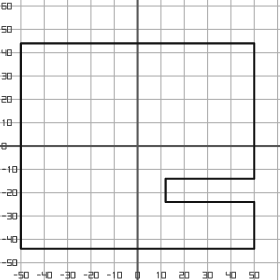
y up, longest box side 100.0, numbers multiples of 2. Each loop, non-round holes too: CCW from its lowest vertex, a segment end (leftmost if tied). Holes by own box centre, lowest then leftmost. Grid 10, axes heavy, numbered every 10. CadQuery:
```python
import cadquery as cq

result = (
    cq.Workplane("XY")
    .moveTo(-50.0, -44.0)
    .lineTo(50.0, -44.0)
    .lineTo(50.0, -24.0)
    .lineTo(12.0, -24.0)
    .lineTo(12.0, -14.0)
    .lineTo(50.0, -14.0)
    .lineTo(50.0, 44.0)
    .lineTo(-50.0, 44.0)
    .close()
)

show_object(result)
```